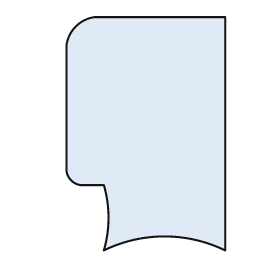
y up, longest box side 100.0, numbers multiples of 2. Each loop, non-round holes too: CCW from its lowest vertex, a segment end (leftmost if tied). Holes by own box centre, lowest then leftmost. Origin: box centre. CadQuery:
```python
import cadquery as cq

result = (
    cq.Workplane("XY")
    .moveTo(-18.0, -50.0)
    .threePointArc((8.0, -44.0), (34.0, -50.0))
    .lineTo(34.0, 50.0)
    .lineTo(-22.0, 50.0)
    .threePointArc((-30.0, 46.0), (-34.0, 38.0))
    .lineTo(-34.0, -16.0)
    .threePointArc((-32.0, -20.0), (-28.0, -22.0))
    .lineTo(-18.0, -22.0)
    .threePointArc((-16.0, -36.0), (-18.0, -50.0))
    .close()
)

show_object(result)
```